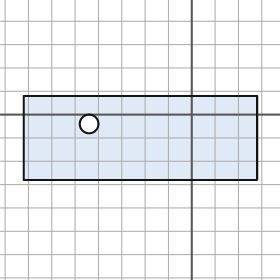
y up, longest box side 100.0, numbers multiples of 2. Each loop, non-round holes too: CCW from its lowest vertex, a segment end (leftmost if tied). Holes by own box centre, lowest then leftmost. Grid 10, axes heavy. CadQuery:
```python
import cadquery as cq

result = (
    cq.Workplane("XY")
    .moveTo(-72.0, -28.0)
    .lineTo(28.0, -28.0)
    .lineTo(28.0, 8.0)
    .lineTo(-72.0, 8.0)
    .close()
    .moveTo(-44.0, -4.0)
    .circle(4.0)
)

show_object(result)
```